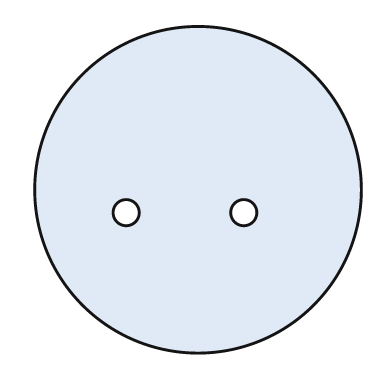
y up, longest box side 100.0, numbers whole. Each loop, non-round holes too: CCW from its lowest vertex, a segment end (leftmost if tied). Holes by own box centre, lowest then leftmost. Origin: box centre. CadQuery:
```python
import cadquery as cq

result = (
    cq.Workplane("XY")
    .moveTo(0.0, 0.0)
    .circle(50.0)
    .moveTo(-22.0, -7.0)
    .circle(4.0)
    .moveTo(14.0, -7.0)
    .circle(4.0)
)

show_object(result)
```